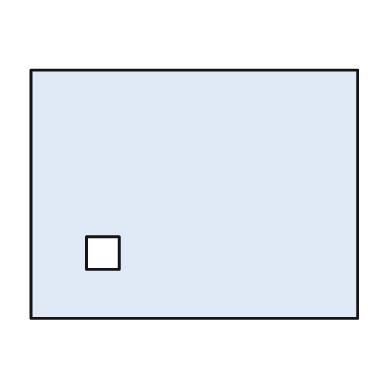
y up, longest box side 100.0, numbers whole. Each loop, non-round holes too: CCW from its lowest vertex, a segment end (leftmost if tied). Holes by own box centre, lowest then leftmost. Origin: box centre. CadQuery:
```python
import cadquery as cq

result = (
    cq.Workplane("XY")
    .moveTo(-50.0, -38.0)
    .lineTo(50.0, -38.0)
    .lineTo(50.0, 38.0)
    .lineTo(-50.0, 38.0)
    .close()
    .moveTo(-33.0, -23.0)
    .lineTo(-23.0, -23.0)
    .lineTo(-23.0, -13.0)
    .lineTo(-33.0, -13.0)
    .close()
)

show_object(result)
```